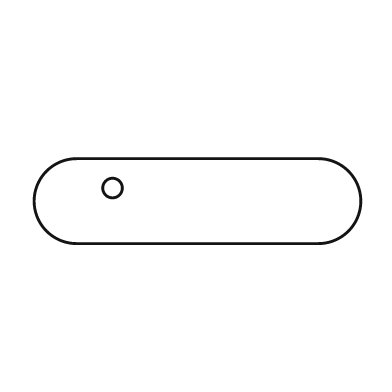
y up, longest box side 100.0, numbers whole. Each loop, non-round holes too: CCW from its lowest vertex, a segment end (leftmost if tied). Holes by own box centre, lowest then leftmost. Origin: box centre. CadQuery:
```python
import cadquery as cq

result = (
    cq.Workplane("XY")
    .moveTo(-37.0, -13.0)
    .lineTo(37.0, -13.0)
    .threePointArc((50.0, 0.0), (37.0, 13.0))
    .lineTo(-37.0, 13.0)
    .threePointArc((-50.0, 0.0), (-37.0, -13.0))
    .close()
    .moveTo(-26.0, 4.0)
    .circle(3.0)
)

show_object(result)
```